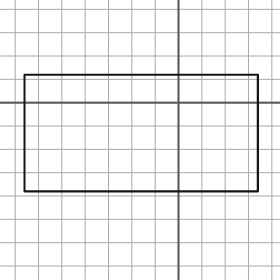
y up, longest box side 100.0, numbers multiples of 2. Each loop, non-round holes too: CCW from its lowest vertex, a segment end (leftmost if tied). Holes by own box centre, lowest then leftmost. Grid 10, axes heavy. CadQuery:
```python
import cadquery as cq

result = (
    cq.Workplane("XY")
    .moveTo(-66.0, -38.0)
    .lineTo(34.0, -38.0)
    .lineTo(34.0, 12.0)
    .lineTo(-66.0, 12.0)
    .close()
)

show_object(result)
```